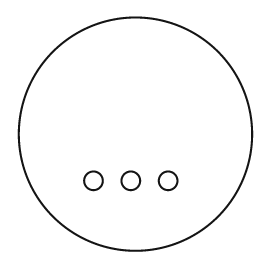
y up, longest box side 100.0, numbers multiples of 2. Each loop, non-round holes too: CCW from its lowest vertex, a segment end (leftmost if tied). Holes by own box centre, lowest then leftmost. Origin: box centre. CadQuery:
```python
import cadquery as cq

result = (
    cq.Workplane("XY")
    .moveTo(0.0, 0.0)
    .circle(50.0)
    .moveTo(-18.0, -20.0)
    .circle(4.0)
    .moveTo(-2.0, -20.0)
    .circle(4.0)
    .moveTo(14.0, -20.0)
    .circle(4.0)
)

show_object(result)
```